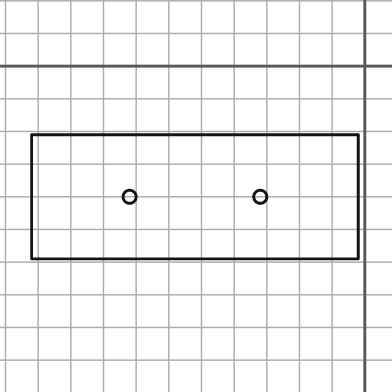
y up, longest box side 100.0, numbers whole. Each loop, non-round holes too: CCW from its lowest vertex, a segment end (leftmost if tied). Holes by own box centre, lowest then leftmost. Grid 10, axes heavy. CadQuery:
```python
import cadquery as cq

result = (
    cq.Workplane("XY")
    .moveTo(-102.0, -59.0)
    .lineTo(-2.0, -59.0)
    .lineTo(-2.0, -21.0)
    .lineTo(-102.0, -21.0)
    .close()
    .moveTo(-72.0, -40.0)
    .circle(2.0)
    .moveTo(-32.0, -40.0)
    .circle(2.0)
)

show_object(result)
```